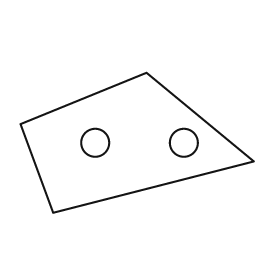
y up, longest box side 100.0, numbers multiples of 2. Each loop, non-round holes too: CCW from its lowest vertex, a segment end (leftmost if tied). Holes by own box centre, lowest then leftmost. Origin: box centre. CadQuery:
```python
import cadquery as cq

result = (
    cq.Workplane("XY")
    .moveTo(-36.0, -30.0)
    .lineTo(50.0, -8.0)
    .lineTo(4.0, 30.0)
    .lineTo(-50.0, 8.0)
    .close()
    .moveTo(-18.0, 0.0)
    .circle(6.0)
    .moveTo(20.0, 0.0)
    .circle(6.0)
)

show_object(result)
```